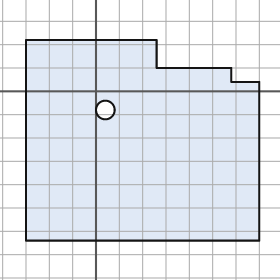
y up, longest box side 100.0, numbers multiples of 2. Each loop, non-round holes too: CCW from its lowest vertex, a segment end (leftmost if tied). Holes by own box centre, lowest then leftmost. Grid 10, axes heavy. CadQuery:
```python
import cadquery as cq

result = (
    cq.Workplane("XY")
    .moveTo(-30.0, -64.0)
    .lineTo(70.0, -64.0)
    .lineTo(70.0, 4.0)
    .lineTo(58.0, 4.0)
    .lineTo(58.0, 10.0)
    .lineTo(26.0, 10.0)
    .lineTo(26.0, 22.0)
    .lineTo(-30.0, 22.0)
    .close()
    .moveTo(4.0, -8.0)
    .circle(4.0)
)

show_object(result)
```